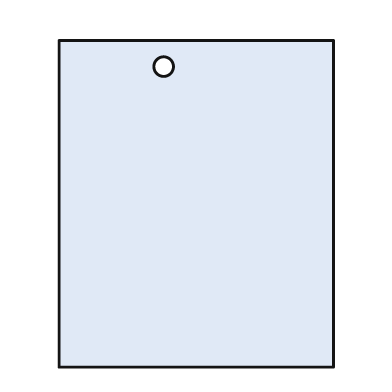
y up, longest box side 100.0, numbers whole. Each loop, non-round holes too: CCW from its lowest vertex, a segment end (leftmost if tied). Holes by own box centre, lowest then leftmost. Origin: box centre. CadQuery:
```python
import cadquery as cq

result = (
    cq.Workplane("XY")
    .moveTo(-42.0, -50.0)
    .lineTo(42.0, -50.0)
    .lineTo(42.0, 50.0)
    .lineTo(-42.0, 50.0)
    .close()
    .moveTo(-10.0, 42.0)
    .circle(3.0)
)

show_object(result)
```